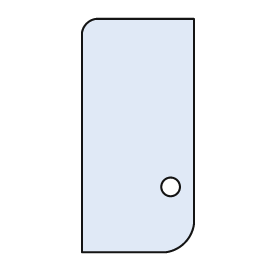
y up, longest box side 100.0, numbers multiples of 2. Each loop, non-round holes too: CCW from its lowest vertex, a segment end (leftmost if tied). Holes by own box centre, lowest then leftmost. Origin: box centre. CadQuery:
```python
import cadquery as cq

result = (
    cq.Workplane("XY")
    .moveTo(-24.0, -50.0)
    .lineTo(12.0, -50.0)
    .threePointArc((20.0, -46.0), (24.0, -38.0))
    .lineTo(24.0, 50.0)
    .lineTo(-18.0, 50.0)
    .threePointArc((-22.0, 48.0), (-24.0, 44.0))
    .close()
    .moveTo(14.0, -22.0)
    .circle(4.0)
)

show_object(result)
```